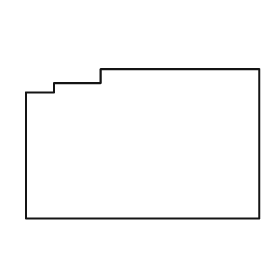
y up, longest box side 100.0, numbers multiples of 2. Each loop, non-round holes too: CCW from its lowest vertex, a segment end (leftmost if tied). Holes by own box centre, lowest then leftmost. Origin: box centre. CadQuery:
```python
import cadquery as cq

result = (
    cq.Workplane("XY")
    .moveTo(-50.0, -32.0)
    .lineTo(50.0, -32.0)
    .lineTo(50.0, 32.0)
    .lineTo(-18.0, 32.0)
    .lineTo(-18.0, 26.0)
    .lineTo(-38.0, 26.0)
    .lineTo(-38.0, 22.0)
    .lineTo(-50.0, 22.0)
    .close()
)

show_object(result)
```